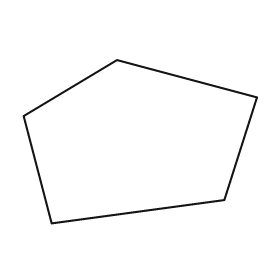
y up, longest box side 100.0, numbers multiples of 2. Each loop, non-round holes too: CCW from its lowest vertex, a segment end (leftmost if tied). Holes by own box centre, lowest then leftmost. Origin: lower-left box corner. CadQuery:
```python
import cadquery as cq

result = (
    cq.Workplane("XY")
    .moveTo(12.0, 0.0)
    .lineTo(86.0, 10.0)
    .lineTo(100.0, 54.0)
    .lineTo(40.0, 70.0)
    .lineTo(0.0, 46.0)
    .close()
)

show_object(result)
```